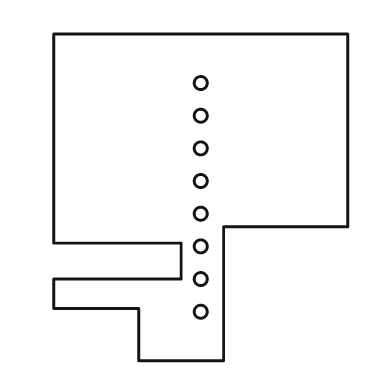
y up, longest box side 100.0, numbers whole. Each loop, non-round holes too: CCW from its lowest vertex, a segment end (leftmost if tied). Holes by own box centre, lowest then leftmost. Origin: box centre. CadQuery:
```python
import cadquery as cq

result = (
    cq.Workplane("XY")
    .moveTo(-19.0, -50.0)
    .lineTo(7.0, -50.0)
    .lineTo(7.0, -9.0)
    .lineTo(45.0, -9.0)
    .lineTo(45.0, 50.0)
    .lineTo(-45.0, 50.0)
    .lineTo(-45.0, -14.0)
    .lineTo(-6.0, -14.0)
    .lineTo(-6.0, -25.0)
    .lineTo(-45.0, -25.0)
    .lineTo(-45.0, -34.0)
    .lineTo(-19.0, -34.0)
    .close()
    .moveTo(0.0, -35.0)
    .circle(2.0)
    .moveTo(0.0, -25.0)
    .circle(2.0)
    .moveTo(0.0, -15.0)
    .circle(2.0)
    .moveTo(0.0, -5.0)
    .circle(2.0)
    .moveTo(0.0, 5.0)
    .circle(2.0)
    .moveTo(0.0, 15.0)
    .circle(2.0)
    .moveTo(0.0, 25.0)
    .circle(2.0)
    .moveTo(0.0, 35.0)
    .circle(2.0)
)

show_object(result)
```